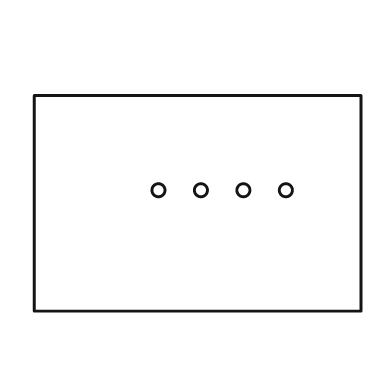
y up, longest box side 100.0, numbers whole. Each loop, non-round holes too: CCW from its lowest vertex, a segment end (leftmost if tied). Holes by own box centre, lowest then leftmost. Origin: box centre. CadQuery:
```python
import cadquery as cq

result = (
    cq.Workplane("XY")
    .moveTo(-50.0, -33.0)
    .lineTo(50.0, -33.0)
    .lineTo(50.0, 33.0)
    .lineTo(-50.0, 33.0)
    .close()
    .moveTo(-12.0, 4.0)
    .circle(2.0)
    .moveTo(1.0, 4.0)
    .circle(2.0)
    .moveTo(14.0, 4.0)
    .circle(2.0)
    .moveTo(27.0, 4.0)
    .circle(2.0)
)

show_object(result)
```